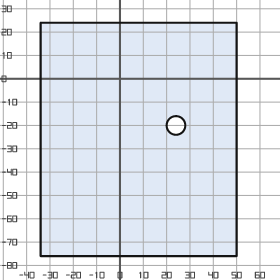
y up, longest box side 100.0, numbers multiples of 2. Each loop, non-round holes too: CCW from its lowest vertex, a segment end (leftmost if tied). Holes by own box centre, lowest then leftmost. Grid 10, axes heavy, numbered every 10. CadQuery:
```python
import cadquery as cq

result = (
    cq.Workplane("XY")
    .moveTo(-34.0, -76.0)
    .lineTo(50.0, -76.0)
    .lineTo(50.0, 24.0)
    .lineTo(-34.0, 24.0)
    .close()
    .moveTo(24.0, -20.0)
    .circle(4.0)
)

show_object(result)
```